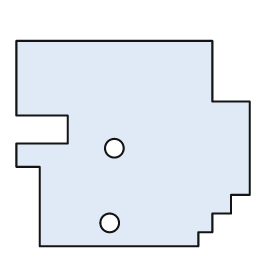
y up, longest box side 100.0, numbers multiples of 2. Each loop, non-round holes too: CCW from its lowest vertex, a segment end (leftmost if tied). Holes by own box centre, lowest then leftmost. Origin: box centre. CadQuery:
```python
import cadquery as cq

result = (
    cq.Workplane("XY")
    .moveTo(-40.0, -44.0)
    .lineTo(28.0, -44.0)
    .lineTo(28.0, -38.0)
    .lineTo(34.0, -38.0)
    .lineTo(34.0, -30.0)
    .lineTo(42.0, -30.0)
    .lineTo(42.0, -22.0)
    .lineTo(50.0, -22.0)
    .lineTo(50.0, 18.0)
    .lineTo(34.0, 18.0)
    .lineTo(34.0, 44.0)
    .lineTo(-50.0, 44.0)
    .lineTo(-50.0, 12.0)
    .lineTo(-28.0, 12.0)
    .lineTo(-28.0, 0.0)
    .lineTo(-50.0, 0.0)
    .lineTo(-50.0, -10.0)
    .lineTo(-40.0, -10.0)
    .close()
    .moveTo(-10.0, -34.0)
    .circle(4.0)
    .moveTo(-8.0, -2.0)
    .circle(4.0)
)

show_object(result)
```